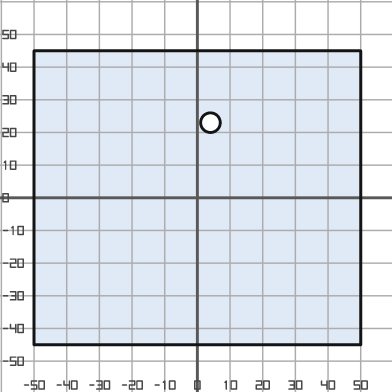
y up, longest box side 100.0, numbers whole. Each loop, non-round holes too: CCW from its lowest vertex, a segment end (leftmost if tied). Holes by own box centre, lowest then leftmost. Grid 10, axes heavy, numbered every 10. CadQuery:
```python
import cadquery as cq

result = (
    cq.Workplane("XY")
    .moveTo(-50.0, -45.0)
    .lineTo(50.0, -45.0)
    .lineTo(50.0, 45.0)
    .lineTo(-50.0, 45.0)
    .close()
    .moveTo(4.0, 23.0)
    .circle(3.0)
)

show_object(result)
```